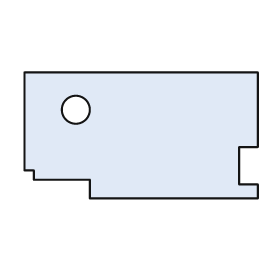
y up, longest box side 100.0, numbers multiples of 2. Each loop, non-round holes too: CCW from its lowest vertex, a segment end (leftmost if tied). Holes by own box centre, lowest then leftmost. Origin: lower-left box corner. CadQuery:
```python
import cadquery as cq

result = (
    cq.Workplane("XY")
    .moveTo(28.0, 0.0)
    .lineTo(100.0, 0.0)
    .lineTo(100.0, 6.0)
    .lineTo(92.0, 6.0)
    .lineTo(92.0, 22.0)
    .lineTo(100.0, 22.0)
    .lineTo(100.0, 54.0)
    .lineTo(0.0, 54.0)
    .lineTo(0.0, 12.0)
    .lineTo(4.0, 12.0)
    .lineTo(4.0, 8.0)
    .lineTo(28.0, 8.0)
    .close()
    .moveTo(22.0, 38.0)
    .circle(6.0)
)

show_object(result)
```